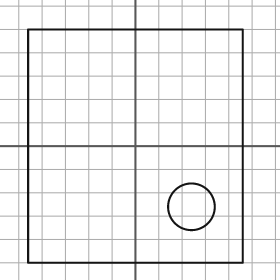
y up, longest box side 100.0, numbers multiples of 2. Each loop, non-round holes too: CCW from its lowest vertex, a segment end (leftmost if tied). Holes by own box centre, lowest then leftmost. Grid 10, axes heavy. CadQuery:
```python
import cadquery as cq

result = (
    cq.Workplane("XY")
    .moveTo(-46.0, -50.0)
    .lineTo(46.0, -50.0)
    .lineTo(46.0, 50.0)
    .lineTo(-46.0, 50.0)
    .close()
    .moveTo(24.0, -26.0)
    .circle(10.0)
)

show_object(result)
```